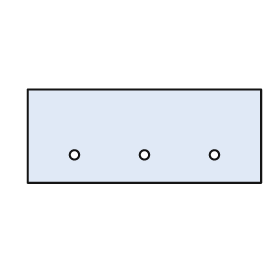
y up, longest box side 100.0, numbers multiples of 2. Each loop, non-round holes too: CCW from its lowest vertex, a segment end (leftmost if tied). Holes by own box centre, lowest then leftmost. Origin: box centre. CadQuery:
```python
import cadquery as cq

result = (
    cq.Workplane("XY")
    .moveTo(-50.0, -20.0)
    .lineTo(50.0, -20.0)
    .lineTo(50.0, 20.0)
    .lineTo(-50.0, 20.0)
    .close()
    .moveTo(-30.0, -8.0)
    .circle(2.0)
    .moveTo(0.0, -8.0)
    .circle(2.0)
    .moveTo(30.0, -8.0)
    .circle(2.0)
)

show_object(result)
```